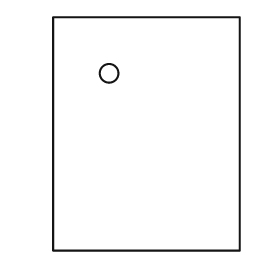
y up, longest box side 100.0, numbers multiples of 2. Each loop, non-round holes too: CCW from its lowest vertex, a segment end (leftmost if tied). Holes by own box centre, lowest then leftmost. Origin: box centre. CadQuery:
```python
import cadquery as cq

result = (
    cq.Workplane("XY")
    .moveTo(-40.0, -50.0)
    .lineTo(40.0, -50.0)
    .lineTo(40.0, 50.0)
    .lineTo(-40.0, 50.0)
    .close()
    .moveTo(-16.0, 26.0)
    .circle(4.0)
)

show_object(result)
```